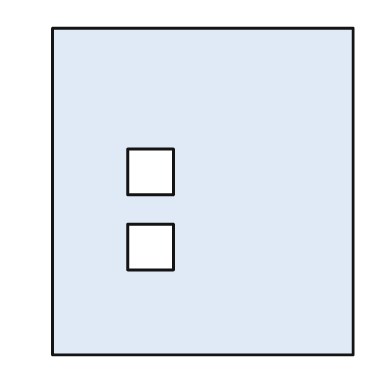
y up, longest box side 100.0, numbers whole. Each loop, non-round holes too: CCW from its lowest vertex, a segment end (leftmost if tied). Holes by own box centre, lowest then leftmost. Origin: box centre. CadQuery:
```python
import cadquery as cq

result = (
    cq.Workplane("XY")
    .moveTo(-46.0, -50.0)
    .lineTo(46.0, -50.0)
    .lineTo(46.0, 50.0)
    .lineTo(-46.0, 50.0)
    .close()
    .moveTo(-23.0, -24.0)
    .lineTo(-9.0, -24.0)
    .lineTo(-9.0, -10.0)
    .lineTo(-23.0, -10.0)
    .close()
    .moveTo(-23.0, -1.0)
    .lineTo(-9.0, -1.0)
    .lineTo(-9.0, 13.0)
    .lineTo(-23.0, 13.0)
    .close()
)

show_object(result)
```